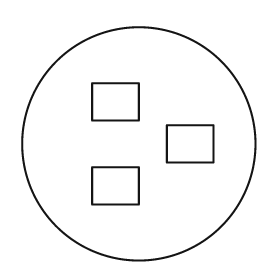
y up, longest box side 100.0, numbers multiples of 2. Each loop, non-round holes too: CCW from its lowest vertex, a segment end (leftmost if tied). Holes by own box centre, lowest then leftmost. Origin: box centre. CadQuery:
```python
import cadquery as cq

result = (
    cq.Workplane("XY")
    .moveTo(0.0, 0.0)
    .circle(50.0)
    .moveTo(-20.0, -26.0)
    .lineTo(0.0, -26.0)
    .lineTo(0.0, -10.0)
    .lineTo(-20.0, -10.0)
    .close()
    .moveTo(12.0, -8.0)
    .lineTo(32.0, -8.0)
    .lineTo(32.0, 8.0)
    .lineTo(12.0, 8.0)
    .close()
    .moveTo(-20.0, 10.0)
    .lineTo(0.0, 10.0)
    .lineTo(0.0, 26.0)
    .lineTo(-20.0, 26.0)
    .close()
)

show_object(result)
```